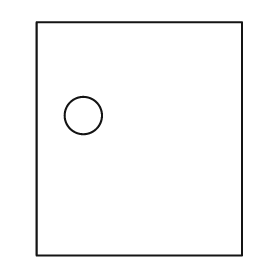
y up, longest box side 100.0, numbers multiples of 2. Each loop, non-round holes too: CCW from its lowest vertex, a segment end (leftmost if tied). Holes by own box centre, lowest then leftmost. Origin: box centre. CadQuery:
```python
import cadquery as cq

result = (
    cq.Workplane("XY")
    .moveTo(-44.0, -50.0)
    .lineTo(44.0, -50.0)
    .lineTo(44.0, 50.0)
    .lineTo(-44.0, 50.0)
    .close()
    .moveTo(-24.0, 10.0)
    .circle(8.0)
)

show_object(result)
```